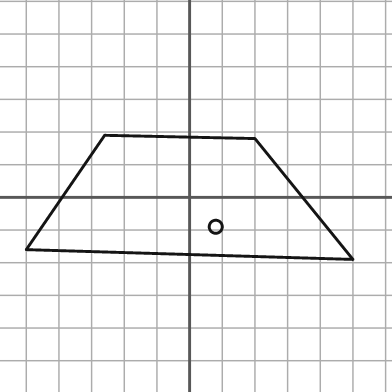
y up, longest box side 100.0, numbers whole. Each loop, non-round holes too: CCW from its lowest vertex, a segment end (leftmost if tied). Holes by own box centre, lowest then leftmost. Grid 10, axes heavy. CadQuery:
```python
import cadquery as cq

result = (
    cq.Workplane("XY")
    .moveTo(50.0, -19.0)
    .lineTo(20.0, 18.0)
    .lineTo(-26.0, 19.0)
    .lineTo(-50.0, -16.0)
    .close()
    .moveTo(8.0, -9.0)
    .circle(2.0)
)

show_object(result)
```